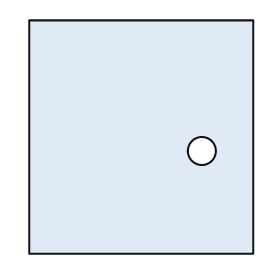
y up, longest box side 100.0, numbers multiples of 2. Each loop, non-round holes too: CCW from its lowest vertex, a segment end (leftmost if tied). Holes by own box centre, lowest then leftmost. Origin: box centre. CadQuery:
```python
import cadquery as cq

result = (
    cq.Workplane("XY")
    .moveTo(-48.0, -50.0)
    .lineTo(48.0, -50.0)
    .lineTo(48.0, 50.0)
    .lineTo(-48.0, 50.0)
    .close()
    .moveTo(26.0, -6.0)
    .circle(6.0)
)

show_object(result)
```